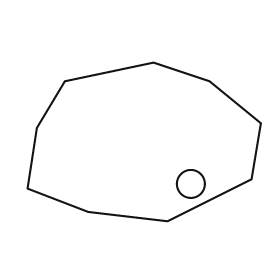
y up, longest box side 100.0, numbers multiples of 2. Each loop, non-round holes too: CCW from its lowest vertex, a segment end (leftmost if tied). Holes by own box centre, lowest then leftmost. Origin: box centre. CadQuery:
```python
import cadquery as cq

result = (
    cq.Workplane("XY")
    .moveTo(10.0, -34.0)
    .lineTo(46.0, -16.0)
    .lineTo(50.0, 8.0)
    .lineTo(28.0, 26.0)
    .lineTo(4.0, 34.0)
    .lineTo(-34.0, 26.0)
    .lineTo(-46.0, 6.0)
    .lineTo(-50.0, -20.0)
    .lineTo(-24.0, -30.0)
    .close()
    .moveTo(20.0, -18.0)
    .circle(6.0)
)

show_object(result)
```